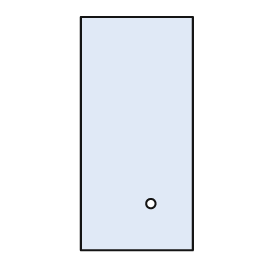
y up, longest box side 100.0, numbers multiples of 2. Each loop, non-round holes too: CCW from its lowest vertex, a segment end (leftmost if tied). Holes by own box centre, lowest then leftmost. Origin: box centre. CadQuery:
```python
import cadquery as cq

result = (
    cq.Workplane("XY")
    .moveTo(-24.0, -50.0)
    .lineTo(24.0, -50.0)
    .lineTo(24.0, 50.0)
    .lineTo(-24.0, 50.0)
    .close()
    .moveTo(6.0, -30.0)
    .circle(2.0)
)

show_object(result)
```